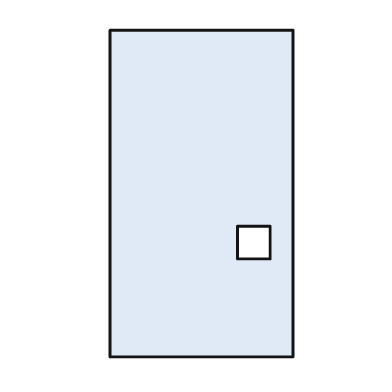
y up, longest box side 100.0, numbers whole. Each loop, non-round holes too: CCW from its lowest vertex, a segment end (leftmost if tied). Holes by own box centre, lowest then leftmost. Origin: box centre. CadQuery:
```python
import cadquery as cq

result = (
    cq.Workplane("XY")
    .moveTo(-28.0, -50.0)
    .lineTo(28.0, -50.0)
    .lineTo(28.0, 50.0)
    .lineTo(-28.0, 50.0)
    .close()
    .moveTo(11.0, -20.0)
    .lineTo(21.0, -20.0)
    .lineTo(21.0, -10.0)
    .lineTo(11.0, -10.0)
    .close()
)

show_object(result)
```